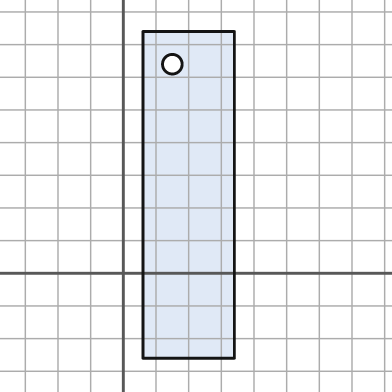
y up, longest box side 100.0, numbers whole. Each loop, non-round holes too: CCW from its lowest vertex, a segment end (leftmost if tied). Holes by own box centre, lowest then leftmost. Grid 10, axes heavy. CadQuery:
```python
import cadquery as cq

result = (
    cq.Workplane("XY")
    .moveTo(6.0, -26.0)
    .lineTo(34.0, -26.0)
    .lineTo(34.0, 74.0)
    .lineTo(6.0, 74.0)
    .close()
    .moveTo(15.0, 64.0)
    .circle(3.0)
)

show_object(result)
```